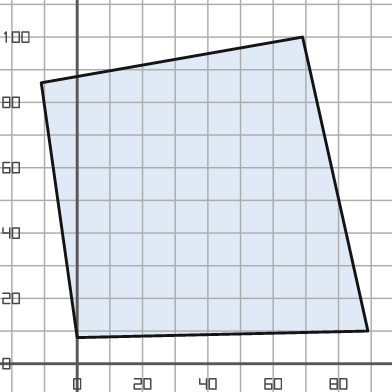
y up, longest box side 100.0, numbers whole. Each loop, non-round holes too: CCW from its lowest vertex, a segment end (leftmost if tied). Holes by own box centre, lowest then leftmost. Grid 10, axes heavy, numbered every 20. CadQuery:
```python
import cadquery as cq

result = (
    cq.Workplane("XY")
    .moveTo(0.0, 8.0)
    .lineTo(89.0, 10.0)
    .lineTo(69.0, 100.0)
    .lineTo(-11.0, 86.0)
    .close()
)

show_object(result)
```